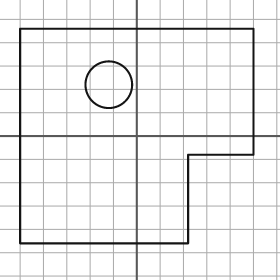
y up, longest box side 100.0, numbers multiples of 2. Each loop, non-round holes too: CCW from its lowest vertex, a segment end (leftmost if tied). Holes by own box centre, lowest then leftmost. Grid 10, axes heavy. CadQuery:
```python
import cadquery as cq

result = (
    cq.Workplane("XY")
    .moveTo(-50.0, -46.0)
    .lineTo(22.0, -46.0)
    .lineTo(22.0, -8.0)
    .lineTo(50.0, -8.0)
    .lineTo(50.0, 46.0)
    .lineTo(-50.0, 46.0)
    .close()
    .moveTo(-12.0, 22.0)
    .circle(10.0)
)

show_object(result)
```